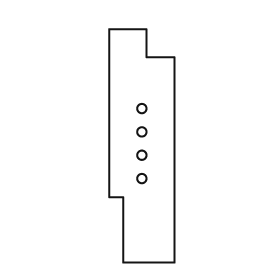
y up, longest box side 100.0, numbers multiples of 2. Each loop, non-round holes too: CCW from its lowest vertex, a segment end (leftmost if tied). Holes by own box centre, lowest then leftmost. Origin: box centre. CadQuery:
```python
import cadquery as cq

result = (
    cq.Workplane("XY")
    .moveTo(-8.0, -50.0)
    .lineTo(14.0, -50.0)
    .lineTo(14.0, 38.0)
    .lineTo(2.0, 38.0)
    .lineTo(2.0, 50.0)
    .lineTo(-14.0, 50.0)
    .lineTo(-14.0, -22.0)
    .lineTo(-8.0, -22.0)
    .close()
    .moveTo(0.0, -14.0)
    .circle(2.0)
    .moveTo(0.0, -4.0)
    .circle(2.0)
    .moveTo(0.0, 6.0)
    .circle(2.0)
    .moveTo(0.0, 16.0)
    .circle(2.0)
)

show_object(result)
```